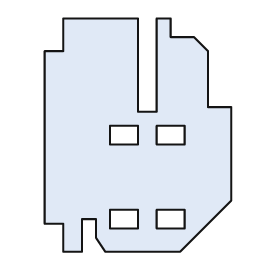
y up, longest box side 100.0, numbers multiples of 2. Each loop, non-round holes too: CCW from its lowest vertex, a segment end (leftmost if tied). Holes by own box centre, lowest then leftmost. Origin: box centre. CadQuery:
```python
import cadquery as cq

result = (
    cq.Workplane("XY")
    .moveTo(-32.0, -50.0)
    .lineTo(-24.0, -50.0)
    .lineTo(-24.0, -36.0)
    .lineTo(-18.0, -36.0)
    .lineTo(-18.0, -44.0)
    .lineTo(-14.0, -50.0)
    .lineTo(18.0, -50.0)
    .lineTo(40.0, -28.0)
    .lineTo(40.0, 12.0)
    .lineTo(30.0, 12.0)
    .lineTo(30.0, 36.0)
    .lineTo(24.0, 42.0)
    .lineTo(14.0, 42.0)
    .lineTo(14.0, 50.0)
    .lineTo(8.0, 50.0)
    .lineTo(8.0, 10.0)
    .lineTo(0.0, 10.0)
    .lineTo(0.0, 50.0)
    .lineTo(-32.0, 50.0)
    .lineTo(-32.0, 36.0)
    .lineTo(-40.0, 36.0)
    .lineTo(-40.0, -38.0)
    .lineTo(-32.0, -38.0)
    .close()
    .moveTo(-12.0, -40.0)
    .lineTo(0.0, -40.0)
    .lineTo(0.0, -32.0)
    .lineTo(-12.0, -32.0)
    .close()
    .moveTo(8.0, -40.0)
    .lineTo(20.0, -40.0)
    .lineTo(20.0, -32.0)
    .lineTo(8.0, -32.0)
    .close()
    .moveTo(-12.0, -4.0)
    .lineTo(0.0, -4.0)
    .lineTo(0.0, 4.0)
    .lineTo(-12.0, 4.0)
    .close()
    .moveTo(8.0, -4.0)
    .lineTo(20.0, -4.0)
    .lineTo(20.0, 4.0)
    .lineTo(8.0, 4.0)
    .close()
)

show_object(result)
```